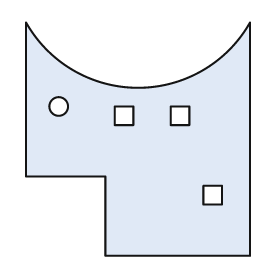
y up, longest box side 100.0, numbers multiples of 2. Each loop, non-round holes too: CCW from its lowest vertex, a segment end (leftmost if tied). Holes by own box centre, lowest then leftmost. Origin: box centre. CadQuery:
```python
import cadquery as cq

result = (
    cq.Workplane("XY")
    .moveTo(-14.0, -50.0)
    .lineTo(48.0, -50.0)
    .lineTo(48.0, 50.0)
    .threePointArc((0.0, 22.0), (-48.0, 50.0))
    .lineTo(-48.0, -16.0)
    .lineTo(-14.0, -16.0)
    .close()
    .moveTo(28.0, -28.0)
    .lineTo(36.0, -28.0)
    .lineTo(36.0, -20.0)
    .lineTo(28.0, -20.0)
    .close()
    .moveTo(-10.0, 6.0)
    .lineTo(-2.0, 6.0)
    .lineTo(-2.0, 14.0)
    .lineTo(-10.0, 14.0)
    .close()
    .moveTo(14.0, 6.0)
    .lineTo(22.0, 6.0)
    .lineTo(22.0, 14.0)
    .lineTo(14.0, 14.0)
    .close()
    .moveTo(-34.0, 14.0)
    .circle(4.0)
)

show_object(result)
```